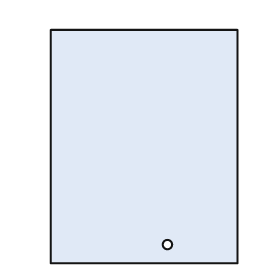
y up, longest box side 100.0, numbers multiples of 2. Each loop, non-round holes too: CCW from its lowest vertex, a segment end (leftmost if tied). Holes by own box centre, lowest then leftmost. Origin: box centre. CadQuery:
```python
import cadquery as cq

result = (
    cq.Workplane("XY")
    .moveTo(-40.0, -50.0)
    .lineTo(40.0, -50.0)
    .lineTo(40.0, 50.0)
    .lineTo(-40.0, 50.0)
    .close()
    .moveTo(10.0, -42.0)
    .circle(2.0)
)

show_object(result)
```